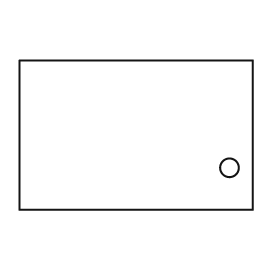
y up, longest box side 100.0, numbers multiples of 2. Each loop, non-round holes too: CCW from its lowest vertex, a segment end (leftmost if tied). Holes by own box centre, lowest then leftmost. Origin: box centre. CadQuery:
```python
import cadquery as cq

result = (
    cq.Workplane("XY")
    .moveTo(-50.0, -32.0)
    .lineTo(50.0, -32.0)
    .lineTo(50.0, 32.0)
    .lineTo(-50.0, 32.0)
    .close()
    .moveTo(40.0, -14.0)
    .circle(4.0)
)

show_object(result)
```